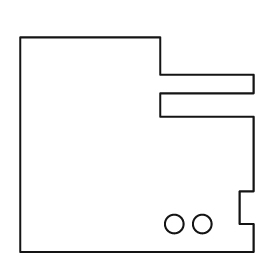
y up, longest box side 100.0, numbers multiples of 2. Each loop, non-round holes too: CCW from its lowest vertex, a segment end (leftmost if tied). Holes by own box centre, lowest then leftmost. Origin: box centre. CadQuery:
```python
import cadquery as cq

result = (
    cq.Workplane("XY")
    .moveTo(-50.0, -46.0)
    .lineTo(50.0, -46.0)
    .lineTo(50.0, -34.0)
    .lineTo(44.0, -34.0)
    .lineTo(44.0, -20.0)
    .lineTo(50.0, -20.0)
    .lineTo(50.0, 12.0)
    .lineTo(10.0, 12.0)
    .lineTo(10.0, 22.0)
    .lineTo(50.0, 22.0)
    .lineTo(50.0, 30.0)
    .lineTo(10.0, 30.0)
    .lineTo(10.0, 46.0)
    .lineTo(-50.0, 46.0)
    .close()
    .moveTo(16.0, -34.0)
    .circle(4.0)
    .moveTo(28.0, -34.0)
    .circle(4.0)
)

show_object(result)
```